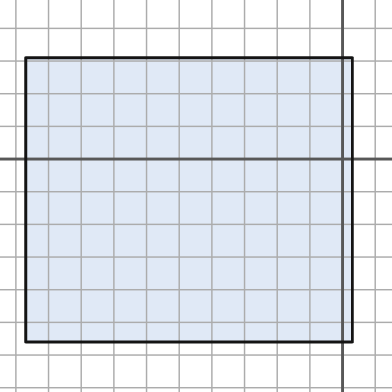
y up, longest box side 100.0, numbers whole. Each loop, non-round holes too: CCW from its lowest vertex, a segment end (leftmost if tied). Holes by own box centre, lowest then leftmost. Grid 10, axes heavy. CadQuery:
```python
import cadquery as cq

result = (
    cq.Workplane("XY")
    .moveTo(-97.0, -56.0)
    .lineTo(3.0, -56.0)
    .lineTo(3.0, 31.0)
    .lineTo(-97.0, 31.0)
    .close()
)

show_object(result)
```